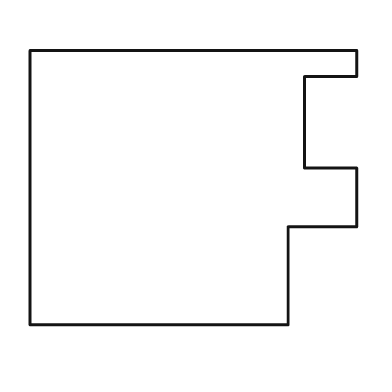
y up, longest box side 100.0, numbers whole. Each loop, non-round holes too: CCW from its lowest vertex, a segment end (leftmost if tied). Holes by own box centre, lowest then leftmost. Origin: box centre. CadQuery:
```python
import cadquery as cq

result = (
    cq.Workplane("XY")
    .moveTo(-50.0, -42.0)
    .lineTo(29.0, -42.0)
    .lineTo(29.0, -12.0)
    .lineTo(50.0, -12.0)
    .lineTo(50.0, 6.0)
    .lineTo(34.0, 6.0)
    .lineTo(34.0, 34.0)
    .lineTo(50.0, 34.0)
    .lineTo(50.0, 42.0)
    .lineTo(-50.0, 42.0)
    .close()
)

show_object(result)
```